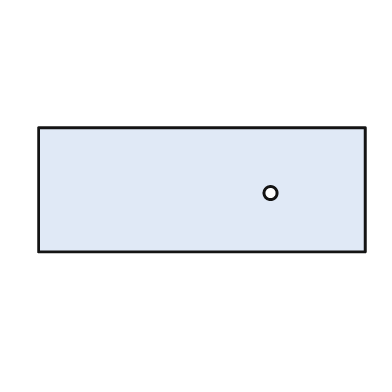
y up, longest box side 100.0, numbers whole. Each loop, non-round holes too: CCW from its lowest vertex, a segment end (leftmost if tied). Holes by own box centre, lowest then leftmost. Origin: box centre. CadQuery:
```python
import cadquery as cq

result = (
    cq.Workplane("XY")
    .moveTo(-50.0, -19.0)
    .lineTo(50.0, -19.0)
    .lineTo(50.0, 19.0)
    .lineTo(-50.0, 19.0)
    .close()
    .moveTo(21.0, -1.0)
    .circle(2.0)
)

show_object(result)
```